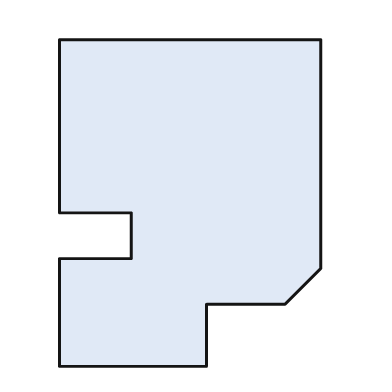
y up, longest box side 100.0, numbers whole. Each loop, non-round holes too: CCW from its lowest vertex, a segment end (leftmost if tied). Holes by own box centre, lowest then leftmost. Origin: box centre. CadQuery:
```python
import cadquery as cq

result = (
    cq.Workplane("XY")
    .moveTo(-40.0, -50.0)
    .lineTo(5.0, -50.0)
    .lineTo(5.0, -31.0)
    .lineTo(29.0, -31.0)
    .lineTo(40.0, -20.0)
    .lineTo(40.0, 50.0)
    .lineTo(-40.0, 50.0)
    .lineTo(-40.0, -3.0)
    .lineTo(-18.0, -3.0)
    .lineTo(-18.0, -17.0)
    .lineTo(-40.0, -17.0)
    .close()
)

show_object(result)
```